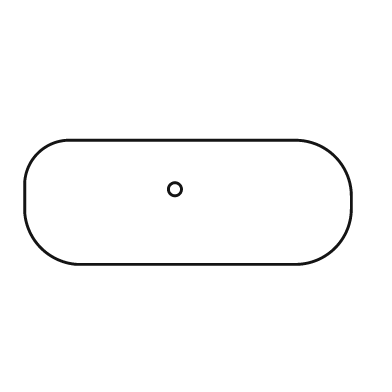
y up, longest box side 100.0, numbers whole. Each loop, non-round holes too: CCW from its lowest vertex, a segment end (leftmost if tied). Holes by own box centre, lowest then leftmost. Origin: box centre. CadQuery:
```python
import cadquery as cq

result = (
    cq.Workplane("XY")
    .moveTo(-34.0, -19.0)
    .lineTo(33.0, -19.0)
    .threePointArc((45.0, -14.0), (50.0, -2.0))
    .lineTo(50.0, 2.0)
    .threePointArc((45.0, 14.0), (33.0, 19.0))
    .lineTo(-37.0, 19.0)
    .threePointArc((-46.0, 15.0), (-50.0, 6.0))
    .lineTo(-50.0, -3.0)
    .threePointArc((-45.0, -14.0), (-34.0, -19.0))
    .close()
    .moveTo(-4.0, 4.0)
    .circle(2.0)
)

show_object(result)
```